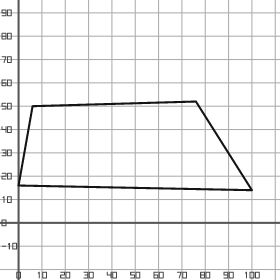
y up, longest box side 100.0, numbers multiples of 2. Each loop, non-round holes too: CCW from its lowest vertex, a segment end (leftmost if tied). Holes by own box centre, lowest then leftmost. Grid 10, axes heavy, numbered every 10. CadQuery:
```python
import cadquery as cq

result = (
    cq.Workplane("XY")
    .moveTo(100.0, 14.0)
    .lineTo(76.0, 52.0)
    .lineTo(6.0, 50.0)
    .lineTo(0.0, 16.0)
    .close()
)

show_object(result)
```